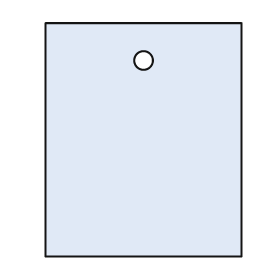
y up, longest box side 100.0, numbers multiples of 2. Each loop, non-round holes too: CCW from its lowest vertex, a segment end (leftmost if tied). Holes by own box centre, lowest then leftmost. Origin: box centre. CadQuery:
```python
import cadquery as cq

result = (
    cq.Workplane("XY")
    .moveTo(-42.0, -50.0)
    .lineTo(42.0, -50.0)
    .lineTo(42.0, 50.0)
    .lineTo(-42.0, 50.0)
    .close()
    .moveTo(0.0, 34.0)
    .circle(4.0)
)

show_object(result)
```